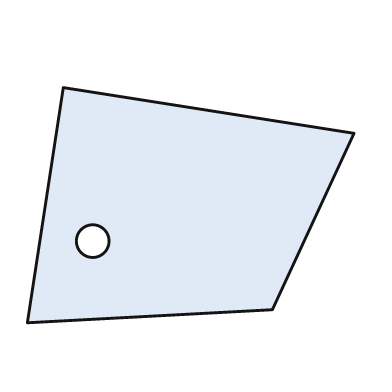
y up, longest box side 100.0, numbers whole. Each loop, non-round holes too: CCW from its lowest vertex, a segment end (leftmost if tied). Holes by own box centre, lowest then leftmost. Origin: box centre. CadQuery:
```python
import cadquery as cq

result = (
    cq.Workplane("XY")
    .moveTo(-50.0, -36.0)
    .lineTo(25.0, -32.0)
    .lineTo(50.0, 22.0)
    .lineTo(-39.0, 36.0)
    .close()
    .moveTo(-30.0, -11.0)
    .circle(5.0)
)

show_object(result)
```